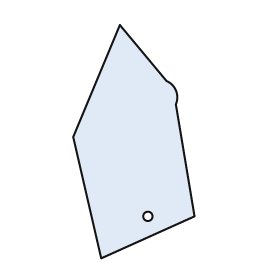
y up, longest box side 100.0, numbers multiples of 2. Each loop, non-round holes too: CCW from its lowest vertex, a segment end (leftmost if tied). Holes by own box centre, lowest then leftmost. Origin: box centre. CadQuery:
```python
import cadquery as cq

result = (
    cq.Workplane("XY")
    .moveTo(-14.0, -50.0)
    .lineTo(26.0, -32.0)
    .lineTo(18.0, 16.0)
    .threePointArc((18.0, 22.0), (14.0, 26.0))
    .lineTo(-6.0, 50.0)
    .lineTo(-26.0, 2.0)
    .close()
    .moveTo(6.0, -32.0)
    .circle(2.0)
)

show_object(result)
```